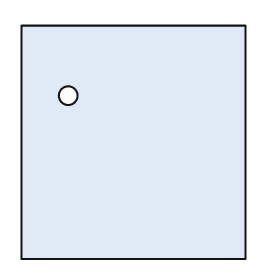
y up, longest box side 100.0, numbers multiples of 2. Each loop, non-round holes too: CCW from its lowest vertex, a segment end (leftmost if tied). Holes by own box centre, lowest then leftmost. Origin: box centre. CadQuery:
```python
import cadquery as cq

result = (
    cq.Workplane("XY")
    .moveTo(-48.0, -50.0)
    .lineTo(48.0, -50.0)
    .lineTo(48.0, 50.0)
    .lineTo(-48.0, 50.0)
    .close()
    .moveTo(-28.0, 20.0)
    .circle(4.0)
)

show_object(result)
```